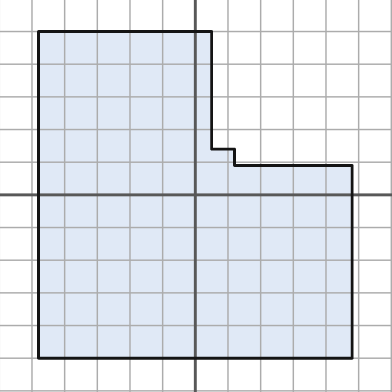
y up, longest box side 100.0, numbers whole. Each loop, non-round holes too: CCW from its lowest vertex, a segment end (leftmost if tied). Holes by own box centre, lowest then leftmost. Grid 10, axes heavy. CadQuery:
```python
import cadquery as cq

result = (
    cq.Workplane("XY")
    .moveTo(-48.0, -50.0)
    .lineTo(48.0, -50.0)
    .lineTo(48.0, 9.0)
    .lineTo(12.0, 9.0)
    .lineTo(12.0, 14.0)
    .lineTo(5.0, 14.0)
    .lineTo(5.0, 50.0)
    .lineTo(-48.0, 50.0)
    .close()
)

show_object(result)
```